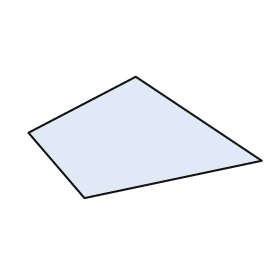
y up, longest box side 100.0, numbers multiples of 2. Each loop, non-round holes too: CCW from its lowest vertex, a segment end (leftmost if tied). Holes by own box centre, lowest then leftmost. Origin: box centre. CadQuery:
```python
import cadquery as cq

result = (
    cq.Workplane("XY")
    .moveTo(-26.0, -26.0)
    .lineTo(50.0, -10.0)
    .lineTo(-4.0, 26.0)
    .lineTo(-50.0, 2.0)
    .close()
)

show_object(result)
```